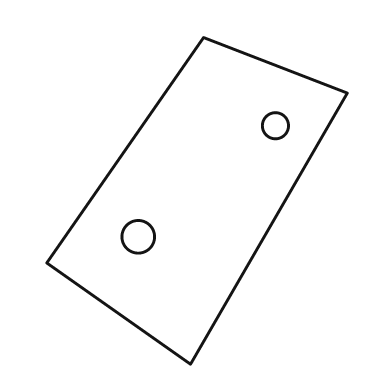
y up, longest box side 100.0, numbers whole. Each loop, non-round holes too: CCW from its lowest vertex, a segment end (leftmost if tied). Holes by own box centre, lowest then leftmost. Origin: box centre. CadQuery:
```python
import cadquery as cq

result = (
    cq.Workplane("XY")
    .moveTo(-2.0, -50.0)
    .lineTo(46.0, 33.0)
    .lineTo(2.0, 50.0)
    .lineTo(-46.0, -19.0)
    .close()
    .moveTo(-18.0, -11.0)
    .circle(5.0)
    .moveTo(24.0, 23.0)
    .circle(4.0)
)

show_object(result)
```